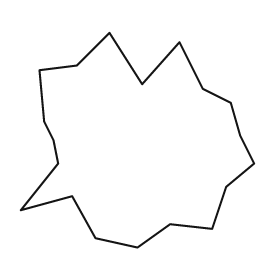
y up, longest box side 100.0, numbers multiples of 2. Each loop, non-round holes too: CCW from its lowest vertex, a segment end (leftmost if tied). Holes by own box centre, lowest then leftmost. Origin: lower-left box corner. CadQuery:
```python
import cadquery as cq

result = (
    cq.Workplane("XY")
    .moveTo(50.0, 0.0)
    .lineTo(64.0, 10.0)
    .lineTo(82.0, 8.0)
    .lineTo(88.0, 26.0)
    .lineTo(100.0, 36.0)
    .lineTo(94.0, 48.0)
    .lineTo(90.0, 62.0)
    .lineTo(78.0, 68.0)
    .lineTo(68.0, 88.0)
    .lineTo(52.0, 70.0)
    .lineTo(38.0, 92.0)
    .lineTo(24.0, 78.0)
    .lineTo(8.0, 76.0)
    .lineTo(10.0, 54.0)
    .lineTo(14.0, 46.0)
    .lineTo(16.0, 36.0)
    .lineTo(0.0, 16.0)
    .lineTo(22.0, 22.0)
    .lineTo(32.0, 4.0)
    .close()
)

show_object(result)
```